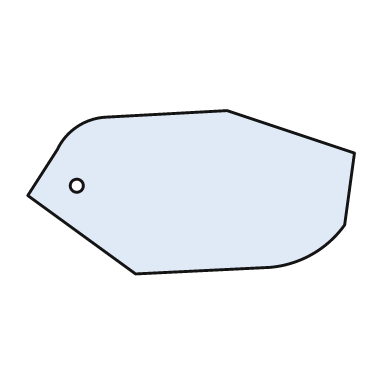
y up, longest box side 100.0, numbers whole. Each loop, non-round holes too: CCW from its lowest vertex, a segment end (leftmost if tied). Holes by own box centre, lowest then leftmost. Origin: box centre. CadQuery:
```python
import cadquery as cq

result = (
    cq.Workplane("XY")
    .moveTo(-17.0, -25.0)
    .lineTo(24.0, -23.0)
    .threePointArc((37.0, -19.0), (47.0, -10.0))
    .lineTo(50.0, 12.0)
    .lineTo(11.0, 25.0)
    .lineTo(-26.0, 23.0)
    .threePointArc((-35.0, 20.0), (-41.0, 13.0))
    .lineTo(-50.0, -1.0)
    .close()
    .moveTo(-35.0, 2.0)
    .circle(2.0)
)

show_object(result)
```